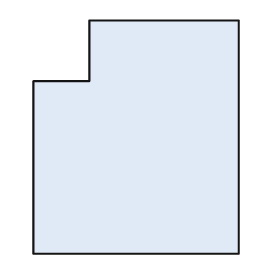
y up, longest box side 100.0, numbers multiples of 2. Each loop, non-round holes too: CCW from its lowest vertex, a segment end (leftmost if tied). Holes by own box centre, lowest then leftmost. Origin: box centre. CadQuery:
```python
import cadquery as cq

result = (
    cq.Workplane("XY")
    .moveTo(-44.0, -50.0)
    .lineTo(44.0, -50.0)
    .lineTo(44.0, 50.0)
    .lineTo(-20.0, 50.0)
    .lineTo(-20.0, 24.0)
    .lineTo(-44.0, 24.0)
    .close()
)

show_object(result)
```